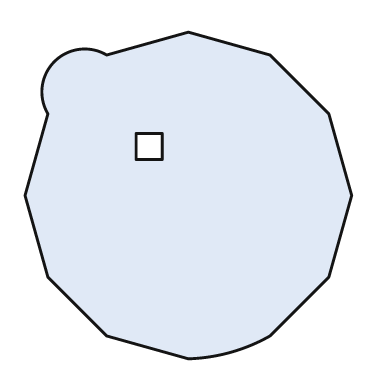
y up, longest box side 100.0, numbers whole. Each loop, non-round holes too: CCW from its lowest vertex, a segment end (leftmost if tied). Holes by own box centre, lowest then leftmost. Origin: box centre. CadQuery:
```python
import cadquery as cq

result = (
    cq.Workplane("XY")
    .moveTo(0.0, -50.0)
    .threePointArc((13.0, -48.0), (25.0, -43.0))
    .lineTo(43.0, -25.0)
    .lineTo(50.0, 0.0)
    .lineTo(43.0, 25.0)
    .lineTo(25.0, 43.0)
    .lineTo(0.0, 50.0)
    .lineTo(-25.0, 43.0)
    .threePointArc((-41.0, 41.0), (-43.0, 25.0))
    .lineTo(-50.0, 0.0)
    .lineTo(-43.0, -25.0)
    .lineTo(-25.0, -43.0)
    .close()
    .moveTo(-16.0, 11.0)
    .lineTo(-8.0, 11.0)
    .lineTo(-8.0, 19.0)
    .lineTo(-16.0, 19.0)
    .close()
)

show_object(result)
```